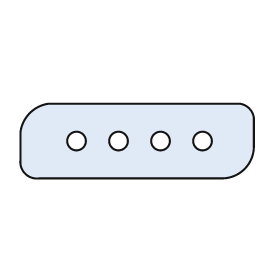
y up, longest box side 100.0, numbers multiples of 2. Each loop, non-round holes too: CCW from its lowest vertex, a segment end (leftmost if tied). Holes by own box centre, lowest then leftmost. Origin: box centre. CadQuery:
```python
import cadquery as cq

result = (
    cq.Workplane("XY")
    .moveTo(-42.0, -16.0)
    .lineTo(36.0, -16.0)
    .threePointArc((46.0, -12.0), (50.0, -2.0))
    .lineTo(50.0, 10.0)
    .threePointArc((48.0, 14.0), (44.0, 16.0))
    .lineTo(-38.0, 16.0)
    .threePointArc((-46.0, 12.0), (-50.0, 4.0))
    .lineTo(-50.0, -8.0)
    .threePointArc((-48.0, -14.0), (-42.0, -16.0))
    .close()
    .moveTo(-26.0, 0.0)
    .circle(4.0)
    .moveTo(-8.0, 0.0)
    .circle(4.0)
    .moveTo(10.0, 0.0)
    .circle(4.0)
    .moveTo(28.0, 0.0)
    .circle(4.0)
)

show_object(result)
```